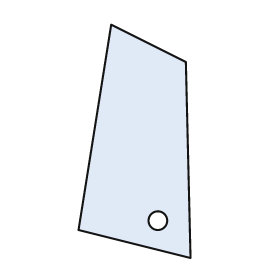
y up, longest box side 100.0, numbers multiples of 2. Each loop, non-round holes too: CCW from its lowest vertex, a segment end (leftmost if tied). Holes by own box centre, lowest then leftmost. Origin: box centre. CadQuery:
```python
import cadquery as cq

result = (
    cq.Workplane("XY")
    .moveTo(24.0, -50.0)
    .lineTo(22.0, 34.0)
    .lineTo(-10.0, 50.0)
    .lineTo(-24.0, -38.0)
    .close()
    .moveTo(10.0, -34.0)
    .circle(4.0)
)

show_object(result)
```